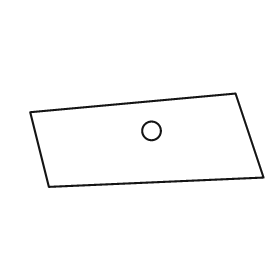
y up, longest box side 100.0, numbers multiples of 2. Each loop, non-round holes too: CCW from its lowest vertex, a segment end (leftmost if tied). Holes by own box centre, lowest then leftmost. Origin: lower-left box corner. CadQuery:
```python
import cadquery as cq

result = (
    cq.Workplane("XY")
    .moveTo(8.0, 0.0)
    .lineTo(100.0, 4.0)
    .lineTo(88.0, 40.0)
    .lineTo(0.0, 32.0)
    .close()
    .moveTo(52.0, 24.0)
    .circle(4.0)
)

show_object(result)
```